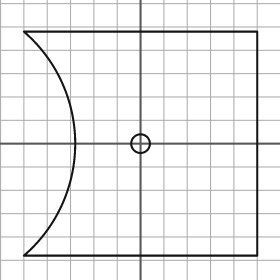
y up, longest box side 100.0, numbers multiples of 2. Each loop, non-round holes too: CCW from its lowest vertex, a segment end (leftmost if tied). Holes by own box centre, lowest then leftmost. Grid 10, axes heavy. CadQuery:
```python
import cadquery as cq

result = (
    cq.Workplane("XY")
    .moveTo(-50.0, -48.0)
    .lineTo(50.0, -48.0)
    .lineTo(50.0, 48.0)
    .lineTo(-50.0, 48.0)
    .threePointArc((-28.0, 0.0), (-50.0, -48.0))
    .close()
    .moveTo(0.0, 0.0)
    .circle(4.0)
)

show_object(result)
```